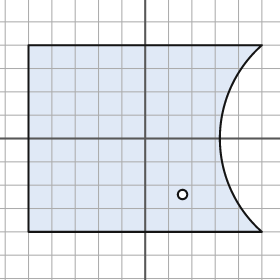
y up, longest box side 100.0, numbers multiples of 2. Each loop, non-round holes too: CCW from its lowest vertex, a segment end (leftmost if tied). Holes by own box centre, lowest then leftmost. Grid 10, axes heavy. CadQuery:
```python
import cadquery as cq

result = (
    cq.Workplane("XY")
    .moveTo(-50.0, -40.0)
    .lineTo(50.0, -40.0)
    .threePointArc((32.0, 0.0), (50.0, 40.0))
    .lineTo(-50.0, 40.0)
    .close()
    .moveTo(16.0, -24.0)
    .circle(2.0)
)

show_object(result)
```